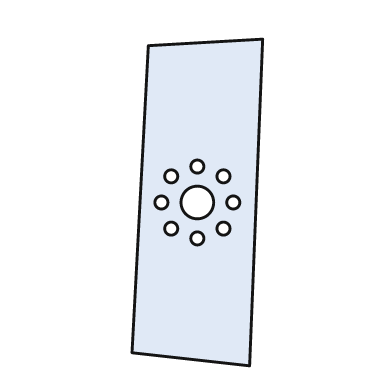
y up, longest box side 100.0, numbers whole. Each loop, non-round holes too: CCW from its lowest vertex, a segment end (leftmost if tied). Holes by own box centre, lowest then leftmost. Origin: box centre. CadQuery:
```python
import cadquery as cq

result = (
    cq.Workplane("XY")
    .moveTo(16.0, -50.0)
    .lineTo(20.0, 50.0)
    .lineTo(-15.0, 48.0)
    .lineTo(-20.0, -46.0)
    .close()
    .moveTo(0.0, -11.0)
    .circle(2.0)
    .moveTo(-8.0, -8.0)
    .circle(2.0)
    .moveTo(8.0, -8.0)
    .circle(2.0)
    .moveTo(-11.0, 0.0)
    .circle(2.0)
    .moveTo(0.0, 0.0)
    .circle(5.0)
    .moveTo(11.0, 0.0)
    .circle(2.0)
    .moveTo(-8.0, 8.0)
    .circle(2.0)
    .moveTo(8.0, 8.0)
    .circle(2.0)
    .moveTo(0.0, 11.0)
    .circle(2.0)
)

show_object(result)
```